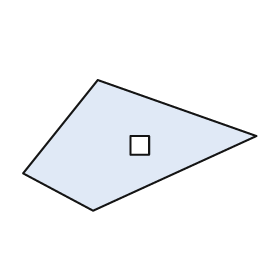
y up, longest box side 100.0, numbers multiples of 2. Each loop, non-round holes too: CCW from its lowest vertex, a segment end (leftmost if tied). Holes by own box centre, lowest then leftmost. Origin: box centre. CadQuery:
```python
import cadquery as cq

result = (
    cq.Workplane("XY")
    .moveTo(-20.0, -28.0)
    .lineTo(50.0, 4.0)
    .lineTo(-18.0, 28.0)
    .lineTo(-50.0, -12.0)
    .close()
    .moveTo(-4.0, -4.0)
    .lineTo(4.0, -4.0)
    .lineTo(4.0, 4.0)
    .lineTo(-4.0, 4.0)
    .close()
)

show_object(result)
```